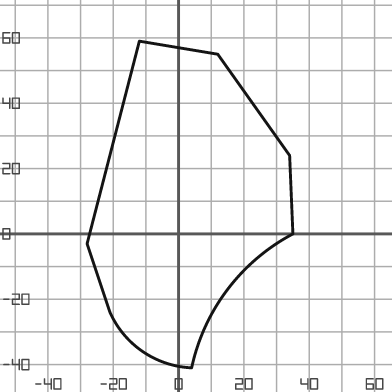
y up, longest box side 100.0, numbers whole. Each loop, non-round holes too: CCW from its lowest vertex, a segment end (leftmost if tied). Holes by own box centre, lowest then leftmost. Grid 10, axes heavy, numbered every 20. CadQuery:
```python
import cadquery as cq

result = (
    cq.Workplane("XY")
    .moveTo(4.0, -41.0)
    .threePointArc((15.0, -17.0), (35.0, 0.0))
    .lineTo(34.0, 24.0)
    .lineTo(12.0, 55.0)
    .lineTo(-12.0, 59.0)
    .lineTo(-28.0, -3.0)
    .lineTo(-21.0, -24.0)
    .threePointArc((-11.0, -36.0), (4.0, -41.0))
    .close()
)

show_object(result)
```